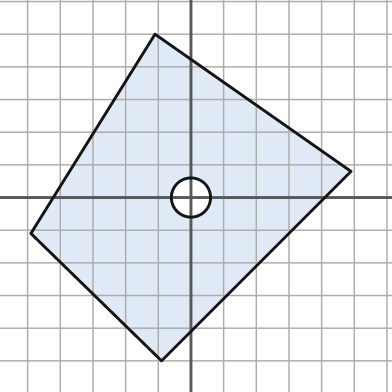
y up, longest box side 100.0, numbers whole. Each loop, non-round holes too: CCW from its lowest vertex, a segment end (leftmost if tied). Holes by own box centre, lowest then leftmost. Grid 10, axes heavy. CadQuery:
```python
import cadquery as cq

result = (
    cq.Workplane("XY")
    .moveTo(-9.0, -50.0)
    .lineTo(49.0, 8.0)
    .lineTo(-11.0, 50.0)
    .lineTo(-49.0, -11.0)
    .close()
    .moveTo(0.0, 0.0)
    .circle(6.0)
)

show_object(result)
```